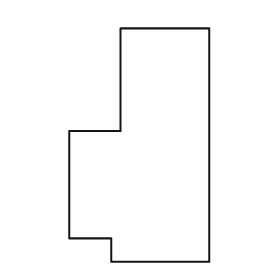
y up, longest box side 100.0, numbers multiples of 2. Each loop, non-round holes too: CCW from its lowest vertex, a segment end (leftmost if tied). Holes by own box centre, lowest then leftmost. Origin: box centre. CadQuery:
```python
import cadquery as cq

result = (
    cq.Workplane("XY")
    .moveTo(-12.0, -50.0)
    .lineTo(30.0, -50.0)
    .lineTo(30.0, 50.0)
    .lineTo(-8.0, 50.0)
    .lineTo(-8.0, 6.0)
    .lineTo(-30.0, 6.0)
    .lineTo(-30.0, -40.0)
    .lineTo(-12.0, -40.0)
    .close()
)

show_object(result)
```